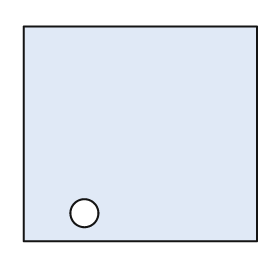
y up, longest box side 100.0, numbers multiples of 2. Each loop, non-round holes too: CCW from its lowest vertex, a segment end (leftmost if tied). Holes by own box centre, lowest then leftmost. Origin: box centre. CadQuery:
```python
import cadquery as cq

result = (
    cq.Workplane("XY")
    .moveTo(-50.0, -46.0)
    .lineTo(50.0, -46.0)
    .lineTo(50.0, 46.0)
    .lineTo(-50.0, 46.0)
    .close()
    .moveTo(-24.0, -34.0)
    .circle(6.0)
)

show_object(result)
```